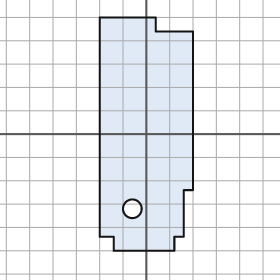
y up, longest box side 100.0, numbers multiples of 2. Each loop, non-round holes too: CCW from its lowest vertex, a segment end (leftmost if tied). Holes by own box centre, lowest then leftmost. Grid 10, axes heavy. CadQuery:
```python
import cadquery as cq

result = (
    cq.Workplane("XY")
    .moveTo(-14.0, -50.0)
    .lineTo(12.0, -50.0)
    .lineTo(12.0, -44.0)
    .lineTo(16.0, -44.0)
    .lineTo(16.0, -24.0)
    .lineTo(20.0, -24.0)
    .lineTo(20.0, 44.0)
    .lineTo(4.0, 44.0)
    .lineTo(4.0, 50.0)
    .lineTo(-20.0, 50.0)
    .lineTo(-20.0, -44.0)
    .lineTo(-14.0, -44.0)
    .close()
    .moveTo(-6.0, -32.0)
    .circle(4.0)
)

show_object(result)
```